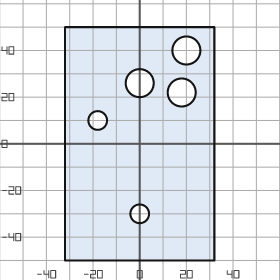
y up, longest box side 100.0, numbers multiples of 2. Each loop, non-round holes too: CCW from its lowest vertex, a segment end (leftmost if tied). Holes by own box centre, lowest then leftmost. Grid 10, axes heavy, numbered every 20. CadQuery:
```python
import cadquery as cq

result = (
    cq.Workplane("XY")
    .moveTo(-32.0, -50.0)
    .lineTo(32.0, -50.0)
    .lineTo(32.0, 50.0)
    .lineTo(-32.0, 50.0)
    .close()
    .moveTo(0.0, -30.0)
    .circle(4.0)
    .moveTo(-18.0, 10.0)
    .circle(4.0)
    .moveTo(18.0, 22.0)
    .circle(6.0)
    .moveTo(0.0, 26.0)
    .circle(6.0)
    .moveTo(20.0, 40.0)
    .circle(6.0)
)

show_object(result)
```